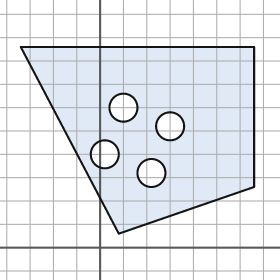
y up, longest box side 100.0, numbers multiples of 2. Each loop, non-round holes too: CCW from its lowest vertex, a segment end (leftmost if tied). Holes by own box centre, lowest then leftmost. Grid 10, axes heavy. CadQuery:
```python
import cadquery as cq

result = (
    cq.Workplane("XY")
    .moveTo(8.0, 6.0)
    .lineTo(66.0, 26.0)
    .lineTo(66.0, 86.0)
    .lineTo(-34.0, 86.0)
    .close()
    .moveTo(22.0, 32.0)
    .circle(6.0)
    .moveTo(2.0, 40.0)
    .circle(6.0)
    .moveTo(30.0, 52.0)
    .circle(6.0)
    .moveTo(10.0, 60.0)
    .circle(6.0)
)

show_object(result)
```